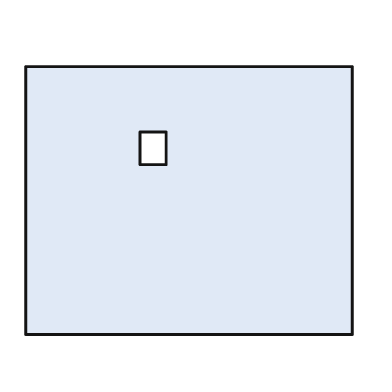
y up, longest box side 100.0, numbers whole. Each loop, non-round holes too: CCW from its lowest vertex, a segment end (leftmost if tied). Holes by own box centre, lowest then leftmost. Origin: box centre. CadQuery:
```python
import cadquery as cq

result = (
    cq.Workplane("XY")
    .moveTo(-50.0, -41.0)
    .lineTo(50.0, -41.0)
    .lineTo(50.0, 41.0)
    .lineTo(-50.0, 41.0)
    .close()
    .moveTo(-15.0, 11.0)
    .lineTo(-7.0, 11.0)
    .lineTo(-7.0, 21.0)
    .lineTo(-15.0, 21.0)
    .close()
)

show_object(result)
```